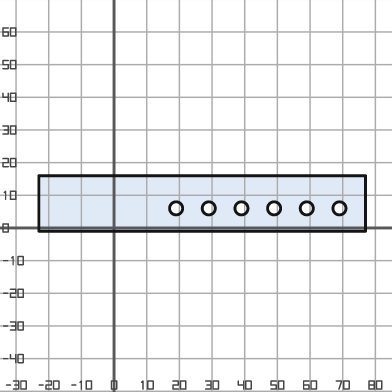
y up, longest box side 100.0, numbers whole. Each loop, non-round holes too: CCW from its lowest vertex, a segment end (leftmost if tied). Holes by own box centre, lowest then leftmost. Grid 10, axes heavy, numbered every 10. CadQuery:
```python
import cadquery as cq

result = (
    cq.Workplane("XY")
    .moveTo(-23.0, -1.0)
    .lineTo(77.0, -1.0)
    .lineTo(77.0, 16.0)
    .lineTo(-23.0, 16.0)
    .close()
    .moveTo(19.0, 6.0)
    .circle(2.0)
    .moveTo(29.0, 6.0)
    .circle(2.0)
    .moveTo(39.0, 6.0)
    .circle(2.0)
    .moveTo(49.0, 6.0)
    .circle(2.0)
    .moveTo(59.0, 6.0)
    .circle(2.0)
    .moveTo(69.0, 6.0)
    .circle(2.0)
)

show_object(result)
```